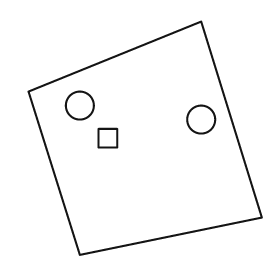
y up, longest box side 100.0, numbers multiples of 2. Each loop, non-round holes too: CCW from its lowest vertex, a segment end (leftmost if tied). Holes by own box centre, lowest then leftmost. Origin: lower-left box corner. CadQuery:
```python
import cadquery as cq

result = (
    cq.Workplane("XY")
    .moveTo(22.0, 0.0)
    .lineTo(100.0, 16.0)
    .lineTo(74.0, 100.0)
    .lineTo(0.0, 70.0)
    .close()
    .moveTo(30.0, 46.0)
    .lineTo(38.0, 46.0)
    .lineTo(38.0, 54.0)
    .lineTo(30.0, 54.0)
    .close()
    .moveTo(74.0, 58.0)
    .circle(6.0)
    .moveTo(22.0, 64.0)
    .circle(6.0)
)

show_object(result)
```